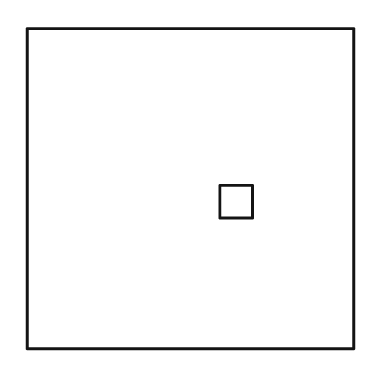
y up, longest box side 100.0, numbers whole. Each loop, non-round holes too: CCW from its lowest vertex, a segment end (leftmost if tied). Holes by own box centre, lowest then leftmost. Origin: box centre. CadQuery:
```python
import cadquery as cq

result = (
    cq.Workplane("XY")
    .moveTo(-50.0, -49.0)
    .lineTo(50.0, -49.0)
    .lineTo(50.0, 49.0)
    .lineTo(-50.0, 49.0)
    .close()
    .moveTo(9.0, -9.0)
    .lineTo(19.0, -9.0)
    .lineTo(19.0, 1.0)
    .lineTo(9.0, 1.0)
    .close()
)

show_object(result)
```